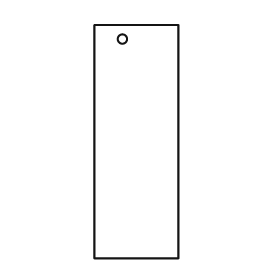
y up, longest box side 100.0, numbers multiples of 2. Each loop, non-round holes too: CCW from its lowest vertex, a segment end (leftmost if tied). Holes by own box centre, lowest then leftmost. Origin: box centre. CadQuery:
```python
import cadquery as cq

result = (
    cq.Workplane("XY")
    .moveTo(-18.0, -50.0)
    .lineTo(18.0, -50.0)
    .lineTo(18.0, 50.0)
    .lineTo(-18.0, 50.0)
    .close()
    .moveTo(-6.0, 44.0)
    .circle(2.0)
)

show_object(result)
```